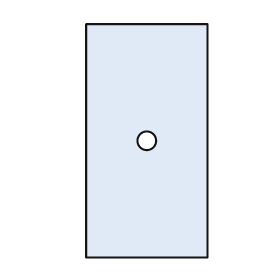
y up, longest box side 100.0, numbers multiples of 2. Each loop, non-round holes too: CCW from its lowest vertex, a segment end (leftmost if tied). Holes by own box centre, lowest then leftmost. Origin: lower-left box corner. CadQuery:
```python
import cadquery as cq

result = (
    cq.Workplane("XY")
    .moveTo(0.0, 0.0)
    .lineTo(52.0, 0.0)
    .lineTo(52.0, 100.0)
    .lineTo(0.0, 100.0)
    .close()
    .moveTo(26.0, 50.0)
    .circle(4.0)
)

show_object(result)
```